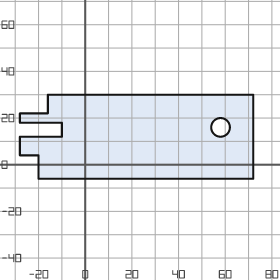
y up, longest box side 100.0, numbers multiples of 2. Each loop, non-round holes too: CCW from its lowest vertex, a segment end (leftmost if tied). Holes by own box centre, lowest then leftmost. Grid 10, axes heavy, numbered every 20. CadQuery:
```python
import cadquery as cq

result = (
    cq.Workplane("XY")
    .moveTo(-20.0, -6.0)
    .lineTo(72.0, -6.0)
    .lineTo(72.0, 30.0)
    .lineTo(-16.0, 30.0)
    .lineTo(-16.0, 22.0)
    .lineTo(-28.0, 22.0)
    .lineTo(-28.0, 18.0)
    .lineTo(-10.0, 18.0)
    .lineTo(-10.0, 12.0)
    .lineTo(-28.0, 12.0)
    .lineTo(-28.0, 4.0)
    .lineTo(-20.0, 4.0)
    .close()
    .moveTo(58.0, 16.0)
    .circle(4.0)
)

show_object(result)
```